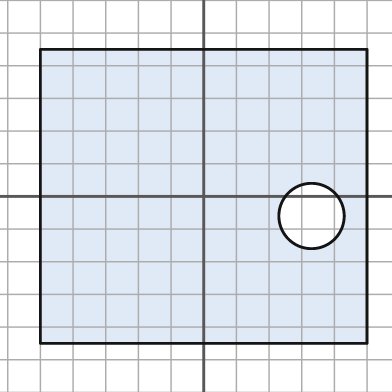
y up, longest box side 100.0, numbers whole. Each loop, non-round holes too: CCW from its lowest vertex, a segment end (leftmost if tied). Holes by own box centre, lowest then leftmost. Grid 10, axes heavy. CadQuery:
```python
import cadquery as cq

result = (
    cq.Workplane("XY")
    .moveTo(-50.0, -45.0)
    .lineTo(50.0, -45.0)
    .lineTo(50.0, 45.0)
    .lineTo(-50.0, 45.0)
    .close()
    .moveTo(33.0, -6.0)
    .circle(10.0)
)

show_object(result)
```